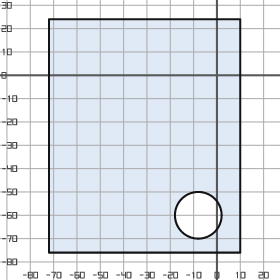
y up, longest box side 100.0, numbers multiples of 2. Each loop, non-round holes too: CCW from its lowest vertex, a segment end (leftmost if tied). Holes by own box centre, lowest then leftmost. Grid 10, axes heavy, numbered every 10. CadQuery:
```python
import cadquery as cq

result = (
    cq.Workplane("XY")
    .moveTo(-72.0, -76.0)
    .lineTo(10.0, -76.0)
    .lineTo(10.0, 24.0)
    .lineTo(-72.0, 24.0)
    .close()
    .moveTo(-8.0, -60.0)
    .circle(10.0)
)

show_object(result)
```